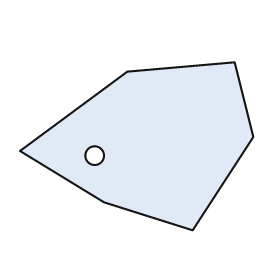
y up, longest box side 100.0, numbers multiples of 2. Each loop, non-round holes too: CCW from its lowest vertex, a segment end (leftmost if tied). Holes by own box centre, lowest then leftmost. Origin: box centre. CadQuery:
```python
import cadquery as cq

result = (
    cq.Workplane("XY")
    .moveTo(24.0, -36.0)
    .lineTo(50.0, 4.0)
    .lineTo(42.0, 36.0)
    .lineTo(-4.0, 32.0)
    .lineTo(-50.0, -2.0)
    .lineTo(-14.0, -24.0)
    .close()
    .moveTo(-18.0, -4.0)
    .circle(4.0)
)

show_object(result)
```